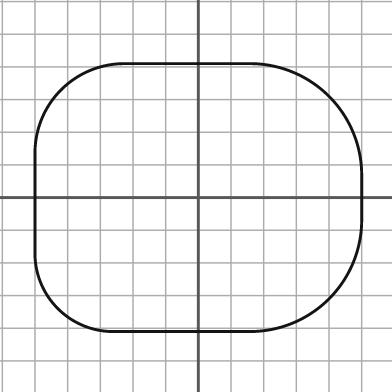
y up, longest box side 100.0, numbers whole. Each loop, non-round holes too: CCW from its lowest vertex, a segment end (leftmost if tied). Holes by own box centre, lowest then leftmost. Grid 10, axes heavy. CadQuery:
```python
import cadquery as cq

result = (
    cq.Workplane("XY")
    .moveTo(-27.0, -41.0)
    .lineTo(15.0, -41.0)
    .threePointArc((40.0, -31.0), (50.0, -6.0))
    .lineTo(50.0, 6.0)
    .threePointArc((40.0, 31.0), (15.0, 41.0))
    .lineTo(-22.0, 41.0)
    .threePointArc((-42.0, 33.0), (-50.0, 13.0))
    .lineTo(-50.0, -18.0)
    .threePointArc((-43.0, -34.0), (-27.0, -41.0))
    .close()
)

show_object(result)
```